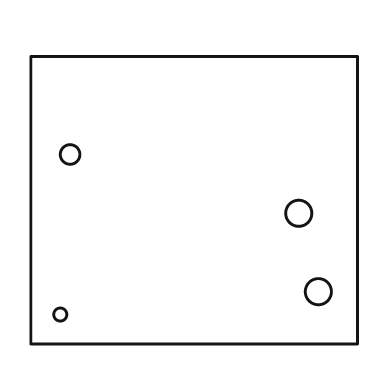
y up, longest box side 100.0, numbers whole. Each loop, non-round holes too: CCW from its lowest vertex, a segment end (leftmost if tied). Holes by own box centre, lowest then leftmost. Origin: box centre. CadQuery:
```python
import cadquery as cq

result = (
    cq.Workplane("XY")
    .moveTo(-50.0, -44.0)
    .lineTo(50.0, -44.0)
    .lineTo(50.0, 44.0)
    .lineTo(-50.0, 44.0)
    .close()
    .moveTo(-41.0, -35.0)
    .circle(2.0)
    .moveTo(38.0, -28.0)
    .circle(4.0)
    .moveTo(32.0, -4.0)
    .circle(4.0)
    .moveTo(-38.0, 14.0)
    .circle(3.0)
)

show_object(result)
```